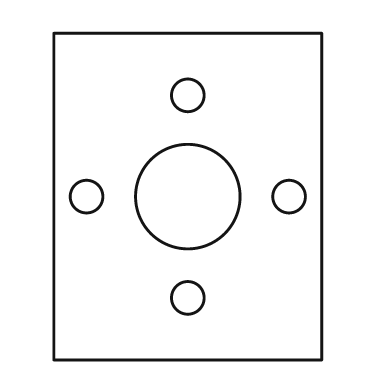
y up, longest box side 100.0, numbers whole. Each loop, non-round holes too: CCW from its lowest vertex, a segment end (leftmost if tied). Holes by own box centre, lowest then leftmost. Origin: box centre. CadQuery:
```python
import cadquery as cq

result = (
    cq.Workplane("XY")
    .moveTo(-41.0, -50.0)
    .lineTo(41.0, -50.0)
    .lineTo(41.0, 50.0)
    .lineTo(-41.0, 50.0)
    .close()
    .moveTo(0.0, -31.0)
    .circle(5.0)
    .moveTo(-31.0, 0.0)
    .circle(5.0)
    .moveTo(0.0, 0.0)
    .circle(16.0)
    .moveTo(31.0, 0.0)
    .circle(5.0)
    .moveTo(0.0, 31.0)
    .circle(5.0)
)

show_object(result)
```